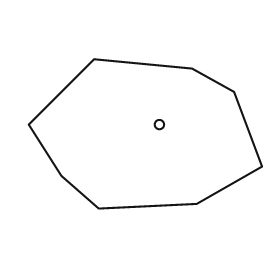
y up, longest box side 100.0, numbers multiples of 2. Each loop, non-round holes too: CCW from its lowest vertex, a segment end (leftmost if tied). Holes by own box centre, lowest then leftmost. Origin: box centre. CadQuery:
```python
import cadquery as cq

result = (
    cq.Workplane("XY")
    .moveTo(-20.0, -32.0)
    .lineTo(22.0, -30.0)
    .lineTo(50.0, -14.0)
    .lineTo(38.0, 18.0)
    .lineTo(20.0, 28.0)
    .lineTo(-22.0, 32.0)
    .lineTo(-50.0, 4.0)
    .lineTo(-36.0, -18.0)
    .close()
    .moveTo(6.0, 4.0)
    .circle(2.0)
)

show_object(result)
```